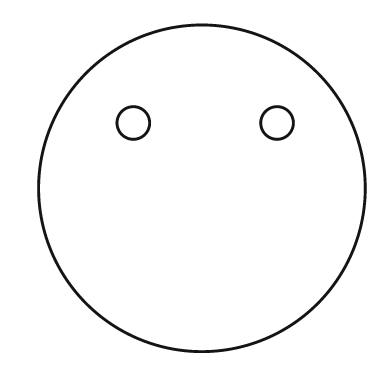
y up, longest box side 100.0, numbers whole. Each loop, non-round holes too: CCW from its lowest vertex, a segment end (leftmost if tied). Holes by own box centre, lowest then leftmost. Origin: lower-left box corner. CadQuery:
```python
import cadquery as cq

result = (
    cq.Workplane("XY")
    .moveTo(50.0, 50.0)
    .circle(50.0)
    .moveTo(29.0, 70.0)
    .circle(5.0)
    .moveTo(73.0, 70.0)
    .circle(5.0)
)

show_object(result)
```